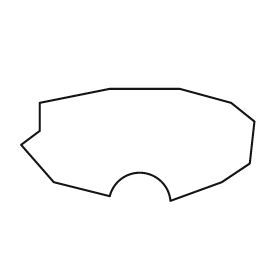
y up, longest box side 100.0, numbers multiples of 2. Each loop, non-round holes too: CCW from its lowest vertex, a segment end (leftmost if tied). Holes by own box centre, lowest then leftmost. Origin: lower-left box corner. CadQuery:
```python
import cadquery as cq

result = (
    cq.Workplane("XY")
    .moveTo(64.0, 0.0)
    .lineTo(86.0, 8.0)
    .lineTo(98.0, 16.0)
    .lineTo(100.0, 34.0)
    .lineTo(90.0, 42.0)
    .lineTo(68.0, 48.0)
    .lineTo(38.0, 48.0)
    .lineTo(8.0, 42.0)
    .lineTo(8.0, 30.0)
    .lineTo(0.0, 24.0)
    .lineTo(14.0, 8.0)
    .lineTo(38.0, 2.0)
    .threePointArc((52.0, 12.0), (64.0, 0.0))
    .close()
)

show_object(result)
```